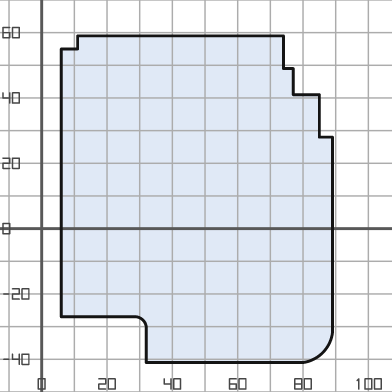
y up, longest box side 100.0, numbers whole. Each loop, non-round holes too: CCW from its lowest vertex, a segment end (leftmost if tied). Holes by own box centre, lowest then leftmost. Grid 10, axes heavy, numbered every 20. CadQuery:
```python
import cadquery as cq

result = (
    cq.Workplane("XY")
    .moveTo(32.0, -41.0)
    .lineTo(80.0, -41.0)
    .threePointArc((86.0, -38.0), (89.0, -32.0))
    .lineTo(89.0, 28.0)
    .lineTo(85.0, 28.0)
    .lineTo(85.0, 41.0)
    .lineTo(77.0, 41.0)
    .lineTo(77.0, 49.0)
    .lineTo(74.0, 49.0)
    .lineTo(74.0, 59.0)
    .lineTo(11.0, 59.0)
    .lineTo(11.0, 55.0)
    .lineTo(6.0, 55.0)
    .lineTo(6.0, -27.0)
    .lineTo(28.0, -27.0)
    .threePointArc((31.0, -28.0), (32.0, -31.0))
    .close()
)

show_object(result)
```